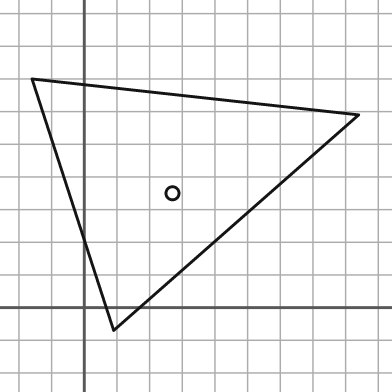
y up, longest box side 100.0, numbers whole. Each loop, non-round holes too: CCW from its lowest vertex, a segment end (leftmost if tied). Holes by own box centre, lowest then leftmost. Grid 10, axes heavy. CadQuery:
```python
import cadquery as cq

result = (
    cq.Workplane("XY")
    .moveTo(9.0, -7.0)
    .lineTo(84.0, 59.0)
    .lineTo(-16.0, 70.0)
    .close()
    .moveTo(27.0, 35.0)
    .circle(2.0)
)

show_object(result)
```